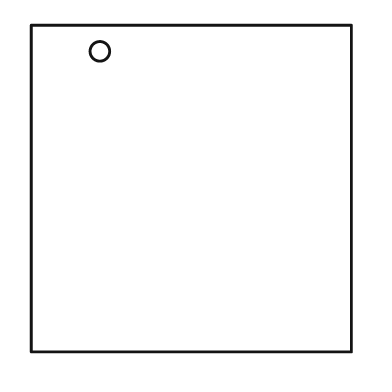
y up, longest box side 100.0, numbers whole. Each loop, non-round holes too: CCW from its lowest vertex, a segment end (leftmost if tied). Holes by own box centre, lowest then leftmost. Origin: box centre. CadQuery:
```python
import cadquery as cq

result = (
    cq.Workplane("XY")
    .moveTo(-49.0, -50.0)
    .lineTo(49.0, -50.0)
    .lineTo(49.0, 50.0)
    .lineTo(-49.0, 50.0)
    .close()
    .moveTo(-28.0, 42.0)
    .circle(3.0)
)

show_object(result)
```